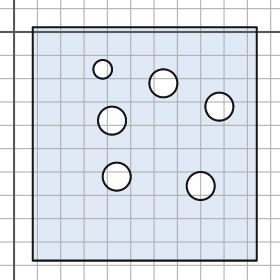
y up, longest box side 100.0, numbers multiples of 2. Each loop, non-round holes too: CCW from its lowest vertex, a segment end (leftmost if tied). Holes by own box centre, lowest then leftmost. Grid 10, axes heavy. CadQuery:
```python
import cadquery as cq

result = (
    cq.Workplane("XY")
    .moveTo(8.0, -98.0)
    .lineTo(104.0, -98.0)
    .lineTo(104.0, 2.0)
    .lineTo(8.0, 2.0)
    .close()
    .moveTo(80.0, -66.0)
    .circle(6.0)
    .moveTo(44.0, -62.0)
    .circle(6.0)
    .moveTo(42.0, -38.0)
    .circle(6.0)
    .moveTo(88.0, -32.0)
    .circle(6.0)
    .moveTo(64.0, -22.0)
    .circle(6.0)
    .moveTo(38.0, -16.0)
    .circle(4.0)
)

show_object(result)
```